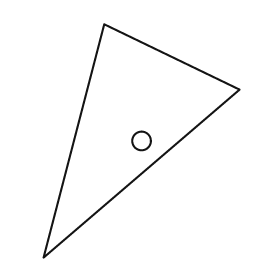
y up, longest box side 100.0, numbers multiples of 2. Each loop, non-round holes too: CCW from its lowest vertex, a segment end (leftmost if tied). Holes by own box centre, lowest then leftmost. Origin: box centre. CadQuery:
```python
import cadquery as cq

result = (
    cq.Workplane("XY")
    .moveTo(-42.0, -50.0)
    .lineTo(42.0, 22.0)
    .lineTo(-16.0, 50.0)
    .close()
    .moveTo(0.0, 0.0)
    .circle(4.0)
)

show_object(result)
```